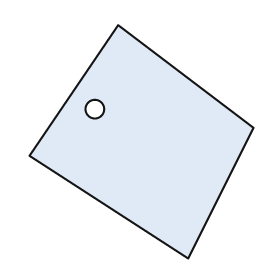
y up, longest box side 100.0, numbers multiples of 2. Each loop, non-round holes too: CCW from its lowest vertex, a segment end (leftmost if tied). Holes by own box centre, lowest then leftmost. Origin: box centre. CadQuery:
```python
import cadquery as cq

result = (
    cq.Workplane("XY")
    .moveTo(20.0, -50.0)
    .lineTo(48.0, 6.0)
    .lineTo(-10.0, 50.0)
    .lineTo(-48.0, -6.0)
    .close()
    .moveTo(-20.0, 14.0)
    .circle(4.0)
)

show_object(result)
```